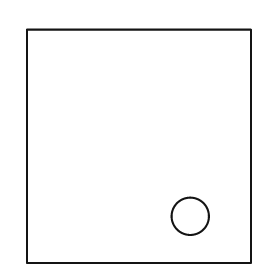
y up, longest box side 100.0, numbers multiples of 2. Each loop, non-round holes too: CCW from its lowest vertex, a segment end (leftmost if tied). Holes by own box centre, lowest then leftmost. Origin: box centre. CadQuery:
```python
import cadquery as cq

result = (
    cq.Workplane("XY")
    .moveTo(-48.0, -50.0)
    .lineTo(48.0, -50.0)
    .lineTo(48.0, 50.0)
    .lineTo(-48.0, 50.0)
    .close()
    .moveTo(22.0, -30.0)
    .circle(8.0)
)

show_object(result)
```